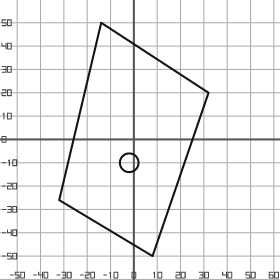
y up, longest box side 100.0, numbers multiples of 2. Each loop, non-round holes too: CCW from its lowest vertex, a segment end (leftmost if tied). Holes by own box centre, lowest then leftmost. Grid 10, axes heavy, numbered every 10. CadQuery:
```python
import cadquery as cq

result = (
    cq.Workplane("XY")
    .moveTo(8.0, -50.0)
    .lineTo(32.0, 20.0)
    .lineTo(-14.0, 50.0)
    .lineTo(-32.0, -26.0)
    .close()
    .moveTo(-2.0, -10.0)
    .circle(4.0)
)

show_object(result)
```